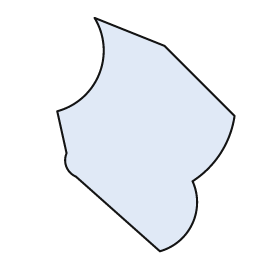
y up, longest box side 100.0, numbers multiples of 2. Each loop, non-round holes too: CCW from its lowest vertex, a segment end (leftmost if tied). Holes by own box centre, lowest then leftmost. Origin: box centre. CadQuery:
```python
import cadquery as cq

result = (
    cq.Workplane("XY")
    .moveTo(6.0, -50.0)
    .threePointArc((20.0, -38.0), (20.0, -20.0))
    .threePointArc((32.0, -8.0), (38.0, 8.0))
    .lineTo(8.0, 38.0)
    .lineTo(-22.0, 50.0)
    .threePointArc((-20.0, 26.0), (-38.0, 10.0))
    .lineTo(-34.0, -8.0)
    .threePointArc((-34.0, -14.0), (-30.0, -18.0))
    .close()
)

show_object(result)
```